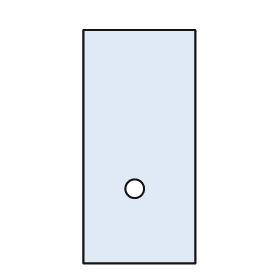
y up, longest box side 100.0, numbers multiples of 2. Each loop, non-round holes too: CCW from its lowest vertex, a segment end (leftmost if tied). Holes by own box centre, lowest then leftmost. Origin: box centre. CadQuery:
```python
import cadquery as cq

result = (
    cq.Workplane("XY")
    .moveTo(-24.0, -50.0)
    .lineTo(24.0, -50.0)
    .lineTo(24.0, 50.0)
    .lineTo(-24.0, 50.0)
    .close()
    .moveTo(-2.0, -18.0)
    .circle(4.0)
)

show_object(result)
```